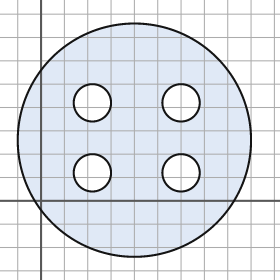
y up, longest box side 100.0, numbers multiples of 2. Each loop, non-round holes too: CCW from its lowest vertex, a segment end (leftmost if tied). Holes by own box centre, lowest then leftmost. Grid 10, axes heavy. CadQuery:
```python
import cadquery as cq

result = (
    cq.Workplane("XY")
    .moveTo(40.0, 26.0)
    .circle(50.0)
    .moveTo(22.0, 12.0)
    .circle(8.0)
    .moveTo(60.0, 12.0)
    .circle(8.0)
    .moveTo(22.0, 42.0)
    .circle(8.0)
    .moveTo(60.0, 42.0)
    .circle(8.0)
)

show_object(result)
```